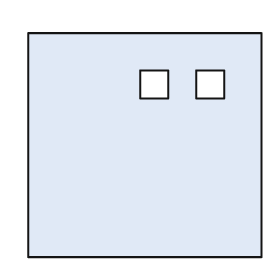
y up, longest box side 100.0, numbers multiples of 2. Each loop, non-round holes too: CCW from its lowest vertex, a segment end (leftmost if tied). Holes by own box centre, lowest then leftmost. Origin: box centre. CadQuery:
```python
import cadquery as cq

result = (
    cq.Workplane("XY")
    .moveTo(-50.0, -48.0)
    .lineTo(50.0, -48.0)
    .lineTo(50.0, 48.0)
    .lineTo(-50.0, 48.0)
    .close()
    .moveTo(-2.0, 20.0)
    .lineTo(10.0, 20.0)
    .lineTo(10.0, 32.0)
    .lineTo(-2.0, 32.0)
    .close()
    .moveTo(22.0, 20.0)
    .lineTo(34.0, 20.0)
    .lineTo(34.0, 32.0)
    .lineTo(22.0, 32.0)
    .close()
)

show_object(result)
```